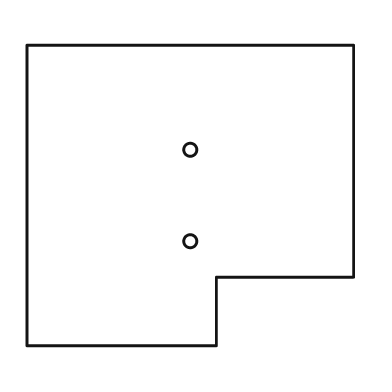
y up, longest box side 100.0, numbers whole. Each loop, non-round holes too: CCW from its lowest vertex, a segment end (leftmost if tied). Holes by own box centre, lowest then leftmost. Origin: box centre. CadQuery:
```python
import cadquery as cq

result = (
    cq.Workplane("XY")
    .moveTo(-50.0, -46.0)
    .lineTo(8.0, -46.0)
    .lineTo(8.0, -25.0)
    .lineTo(50.0, -25.0)
    .lineTo(50.0, 46.0)
    .lineTo(-50.0, 46.0)
    .close()
    .moveTo(0.0, -14.0)
    .circle(2.0)
    .moveTo(0.0, 14.0)
    .circle(2.0)
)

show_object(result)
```